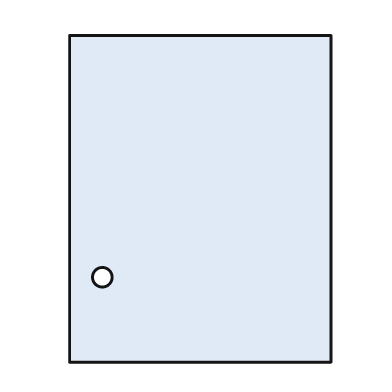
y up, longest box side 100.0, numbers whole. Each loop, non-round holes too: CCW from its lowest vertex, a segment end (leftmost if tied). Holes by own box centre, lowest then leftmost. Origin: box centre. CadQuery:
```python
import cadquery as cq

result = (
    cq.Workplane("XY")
    .moveTo(-40.0, -50.0)
    .lineTo(40.0, -50.0)
    .lineTo(40.0, 50.0)
    .lineTo(-40.0, 50.0)
    .close()
    .moveTo(-30.0, -24.0)
    .circle(3.0)
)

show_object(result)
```